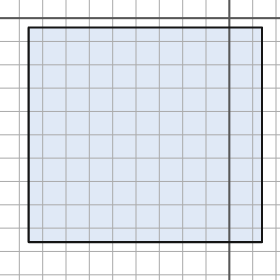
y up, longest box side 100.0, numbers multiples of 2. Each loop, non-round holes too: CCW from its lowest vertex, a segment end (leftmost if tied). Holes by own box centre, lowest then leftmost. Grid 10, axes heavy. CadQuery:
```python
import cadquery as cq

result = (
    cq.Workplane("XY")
    .moveTo(-86.0, -96.0)
    .lineTo(14.0, -96.0)
    .lineTo(14.0, -4.0)
    .lineTo(-86.0, -4.0)
    .close()
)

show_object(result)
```